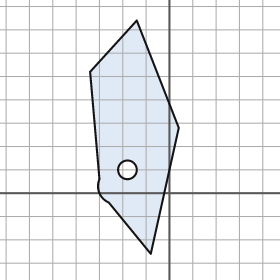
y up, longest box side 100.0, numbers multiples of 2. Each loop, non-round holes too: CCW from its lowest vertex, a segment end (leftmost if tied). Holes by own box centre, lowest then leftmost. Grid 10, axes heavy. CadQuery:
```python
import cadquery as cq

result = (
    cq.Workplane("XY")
    .moveTo(-8.0, -26.0)
    .lineTo(4.0, 28.0)
    .lineTo(-14.0, 74.0)
    .lineTo(-34.0, 52.0)
    .lineTo(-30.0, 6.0)
    .threePointArc((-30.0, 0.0), (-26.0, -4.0))
    .close()
    .moveTo(-18.0, 10.0)
    .circle(4.0)
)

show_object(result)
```